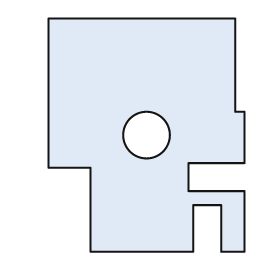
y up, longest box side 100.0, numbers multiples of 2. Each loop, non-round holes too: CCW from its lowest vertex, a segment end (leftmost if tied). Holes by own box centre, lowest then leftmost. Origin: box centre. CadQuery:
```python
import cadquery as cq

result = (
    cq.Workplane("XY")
    .moveTo(-24.0, -50.0)
    .lineTo(20.0, -50.0)
    .lineTo(20.0, -30.0)
    .lineTo(32.0, -30.0)
    .lineTo(32.0, -50.0)
    .lineTo(42.0, -50.0)
    .lineTo(42.0, -24.0)
    .lineTo(18.0, -24.0)
    .lineTo(18.0, -12.0)
    .lineTo(42.0, -12.0)
    .lineTo(42.0, 10.0)
    .lineTo(38.0, 10.0)
    .lineTo(38.0, 50.0)
    .lineTo(-42.0, 50.0)
    .lineTo(-42.0, -14.0)
    .lineTo(-24.0, -14.0)
    .close()
    .moveTo(0.0, 0.0)
    .circle(10.0)
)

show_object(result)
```